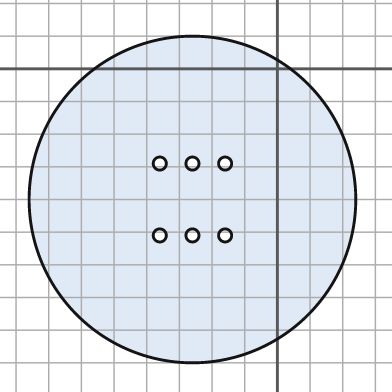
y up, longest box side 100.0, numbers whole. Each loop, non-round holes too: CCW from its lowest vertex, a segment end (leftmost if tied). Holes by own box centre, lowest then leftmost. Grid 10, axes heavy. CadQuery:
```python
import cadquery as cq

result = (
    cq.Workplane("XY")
    .moveTo(-26.0, -40.0)
    .circle(50.0)
    .moveTo(-36.0, -51.0)
    .circle(2.0)
    .moveTo(-26.0, -51.0)
    .circle(2.0)
    .moveTo(-16.0, -51.0)
    .circle(2.0)
    .moveTo(-36.0, -29.0)
    .circle(2.0)
    .moveTo(-26.0, -29.0)
    .circle(2.0)
    .moveTo(-16.0, -29.0)
    .circle(2.0)
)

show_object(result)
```